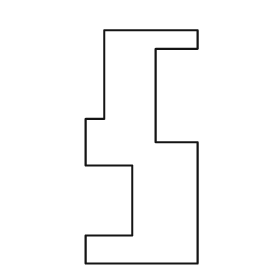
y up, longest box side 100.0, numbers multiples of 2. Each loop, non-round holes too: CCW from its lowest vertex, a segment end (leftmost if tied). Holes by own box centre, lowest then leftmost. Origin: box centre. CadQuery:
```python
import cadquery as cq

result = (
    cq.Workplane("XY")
    .moveTo(-24.0, -50.0)
    .lineTo(24.0, -50.0)
    .lineTo(24.0, 2.0)
    .lineTo(6.0, 2.0)
    .lineTo(6.0, 42.0)
    .lineTo(24.0, 42.0)
    .lineTo(24.0, 50.0)
    .lineTo(-16.0, 50.0)
    .lineTo(-16.0, 12.0)
    .lineTo(-24.0, 12.0)
    .lineTo(-24.0, -8.0)
    .lineTo(-4.0, -8.0)
    .lineTo(-4.0, -38.0)
    .lineTo(-24.0, -38.0)
    .close()
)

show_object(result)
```